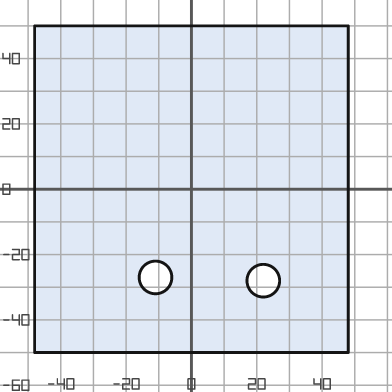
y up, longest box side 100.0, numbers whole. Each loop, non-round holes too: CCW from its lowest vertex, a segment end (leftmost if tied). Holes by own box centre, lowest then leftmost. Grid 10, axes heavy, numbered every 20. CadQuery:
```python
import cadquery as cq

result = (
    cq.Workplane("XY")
    .moveTo(-48.0, -50.0)
    .lineTo(48.0, -50.0)
    .lineTo(48.0, 50.0)
    .lineTo(-48.0, 50.0)
    .close()
    .moveTo(22.0, -28.0)
    .circle(5.0)
    .moveTo(-11.0, -27.0)
    .circle(5.0)
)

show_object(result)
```